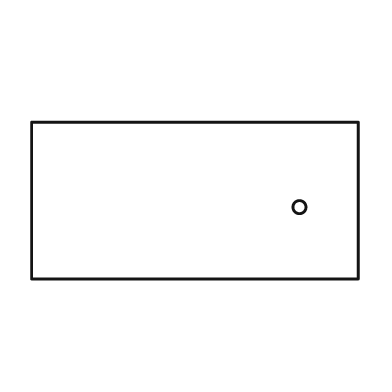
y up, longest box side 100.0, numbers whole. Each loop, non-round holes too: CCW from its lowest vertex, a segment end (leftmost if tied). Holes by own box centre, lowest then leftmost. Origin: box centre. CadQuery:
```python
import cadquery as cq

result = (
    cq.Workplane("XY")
    .moveTo(-50.0, -24.0)
    .lineTo(50.0, -24.0)
    .lineTo(50.0, 24.0)
    .lineTo(-50.0, 24.0)
    .close()
    .moveTo(32.0, -2.0)
    .circle(2.0)
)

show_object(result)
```